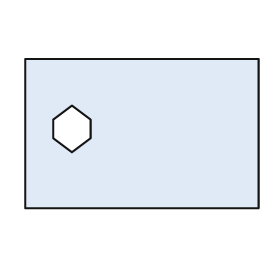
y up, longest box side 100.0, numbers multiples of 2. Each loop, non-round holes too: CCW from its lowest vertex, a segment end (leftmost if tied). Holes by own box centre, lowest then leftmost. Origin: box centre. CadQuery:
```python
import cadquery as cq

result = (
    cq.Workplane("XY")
    .moveTo(-50.0, -32.0)
    .lineTo(50.0, -32.0)
    .lineTo(50.0, 32.0)
    .lineTo(-50.0, 32.0)
    .close()
    .moveTo(-30.0, -8.0)
    .lineTo(-22.0, -2.0)
    .lineTo(-22.0, 6.0)
    .lineTo(-30.0, 12.0)
    .lineTo(-38.0, 6.0)
    .lineTo(-38.0, -2.0)
    .close()
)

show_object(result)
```